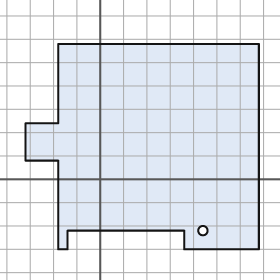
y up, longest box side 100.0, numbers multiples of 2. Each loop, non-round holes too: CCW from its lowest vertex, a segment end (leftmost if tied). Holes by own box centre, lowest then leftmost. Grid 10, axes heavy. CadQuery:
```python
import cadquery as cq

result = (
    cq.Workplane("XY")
    .moveTo(-18.0, -30.0)
    .lineTo(-14.0, -30.0)
    .lineTo(-14.0, -22.0)
    .lineTo(36.0, -22.0)
    .lineTo(36.0, -30.0)
    .lineTo(68.0, -30.0)
    .lineTo(68.0, 58.0)
    .lineTo(-18.0, 58.0)
    .lineTo(-18.0, 24.0)
    .lineTo(-32.0, 24.0)
    .lineTo(-32.0, 8.0)
    .lineTo(-18.0, 8.0)
    .close()
    .moveTo(44.0, -22.0)
    .circle(2.0)
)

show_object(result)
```